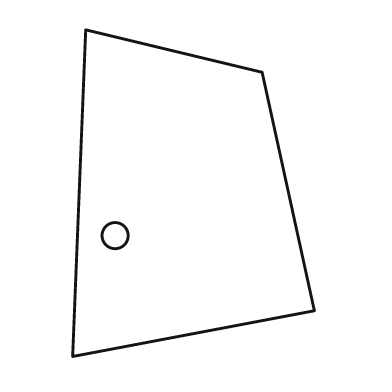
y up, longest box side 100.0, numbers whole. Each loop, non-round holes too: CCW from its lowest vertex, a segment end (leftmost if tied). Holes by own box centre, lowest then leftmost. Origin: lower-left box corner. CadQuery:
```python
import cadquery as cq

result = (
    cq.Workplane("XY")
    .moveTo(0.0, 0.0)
    .lineTo(74.0, 14.0)
    .lineTo(58.0, 87.0)
    .lineTo(4.0, 100.0)
    .close()
    .moveTo(13.0, 37.0)
    .circle(4.0)
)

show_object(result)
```